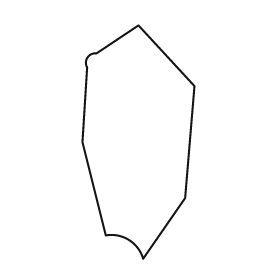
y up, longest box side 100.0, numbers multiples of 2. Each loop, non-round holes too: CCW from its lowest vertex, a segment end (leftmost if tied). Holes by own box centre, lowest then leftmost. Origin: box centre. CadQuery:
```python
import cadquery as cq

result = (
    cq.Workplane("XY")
    .moveTo(2.0, -50.0)
    .lineTo(20.0, -24.0)
    .lineTo(24.0, 24.0)
    .lineTo(0.0, 50.0)
    .lineTo(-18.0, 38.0)
    .threePointArc((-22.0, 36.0), (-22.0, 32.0))
    .lineTo(-24.0, 0.0)
    .lineTo(-14.0, -40.0)
    .threePointArc((-4.0, -42.0), (2.0, -50.0))
    .close()
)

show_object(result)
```